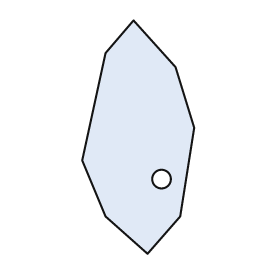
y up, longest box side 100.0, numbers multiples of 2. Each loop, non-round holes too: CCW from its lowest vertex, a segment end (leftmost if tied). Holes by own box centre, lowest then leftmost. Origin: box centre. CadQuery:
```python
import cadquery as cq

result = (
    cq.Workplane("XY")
    .moveTo(4.0, -50.0)
    .lineTo(18.0, -34.0)
    .lineTo(24.0, 4.0)
    .lineTo(16.0, 30.0)
    .lineTo(-2.0, 50.0)
    .lineTo(-14.0, 36.0)
    .lineTo(-24.0, -10.0)
    .lineTo(-14.0, -34.0)
    .close()
    .moveTo(10.0, -18.0)
    .circle(4.0)
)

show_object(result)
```